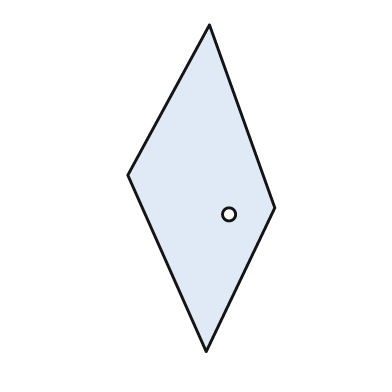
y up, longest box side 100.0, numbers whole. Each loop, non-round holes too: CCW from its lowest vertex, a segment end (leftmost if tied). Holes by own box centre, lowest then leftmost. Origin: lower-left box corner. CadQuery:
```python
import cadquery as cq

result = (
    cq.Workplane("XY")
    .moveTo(24.0, 0.0)
    .lineTo(45.0, 44.0)
    .lineTo(25.0, 100.0)
    .lineTo(0.0, 54.0)
    .close()
    .moveTo(31.0, 42.0)
    .circle(2.0)
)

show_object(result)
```